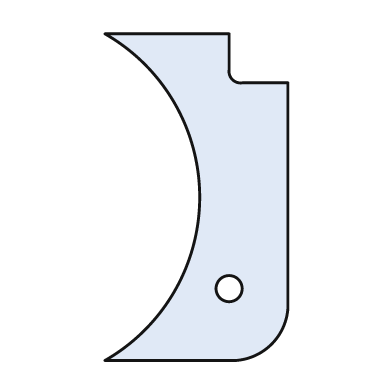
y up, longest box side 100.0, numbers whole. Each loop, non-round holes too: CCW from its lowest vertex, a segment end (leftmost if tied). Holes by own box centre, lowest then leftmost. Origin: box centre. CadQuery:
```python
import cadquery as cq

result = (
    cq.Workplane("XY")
    .moveTo(-28.0, -50.0)
    .lineTo(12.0, -50.0)
    .threePointArc((23.0, -45.0), (28.0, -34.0))
    .lineTo(28.0, 35.0)
    .lineTo(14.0, 35.0)
    .threePointArc((11.0, 36.0), (10.0, 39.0))
    .lineTo(10.0, 50.0)
    .lineTo(-28.0, 50.0)
    .threePointArc((1.0, 0.0), (-28.0, -50.0))
    .close()
    .moveTo(10.0, -28.0)
    .circle(4.0)
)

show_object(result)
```